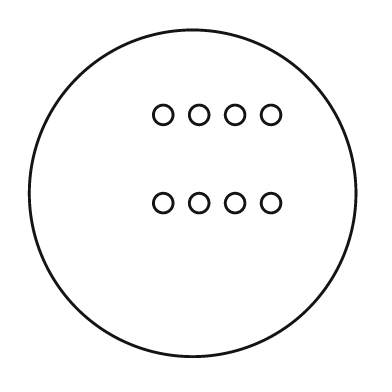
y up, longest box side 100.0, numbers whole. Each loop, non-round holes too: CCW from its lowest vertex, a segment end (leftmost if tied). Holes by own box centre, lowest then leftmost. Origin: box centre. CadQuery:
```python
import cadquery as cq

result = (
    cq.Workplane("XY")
    .moveTo(0.0, 0.0)
    .circle(50.0)
    .moveTo(-9.0, -3.0)
    .circle(3.0)
    .moveTo(2.0, -3.0)
    .circle(3.0)
    .moveTo(13.0, -3.0)
    .circle(3.0)
    .moveTo(24.0, -3.0)
    .circle(3.0)
    .moveTo(-9.0, 24.0)
    .circle(3.0)
    .moveTo(2.0, 24.0)
    .circle(3.0)
    .moveTo(13.0, 24.0)
    .circle(3.0)
    .moveTo(24.0, 24.0)
    .circle(3.0)
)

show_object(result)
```